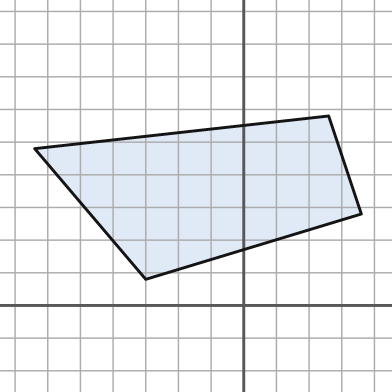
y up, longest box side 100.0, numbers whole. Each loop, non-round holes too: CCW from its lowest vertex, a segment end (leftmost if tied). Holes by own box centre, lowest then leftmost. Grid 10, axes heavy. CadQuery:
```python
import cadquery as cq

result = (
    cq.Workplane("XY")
    .moveTo(-30.0, 8.0)
    .lineTo(36.0, 28.0)
    .lineTo(26.0, 58.0)
    .lineTo(-64.0, 48.0)
    .close()
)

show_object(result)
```